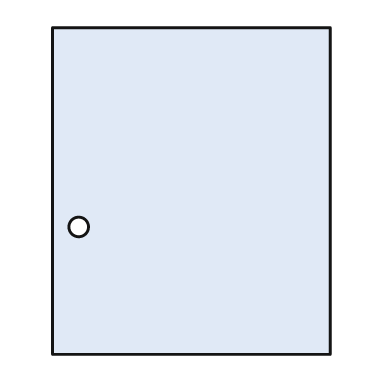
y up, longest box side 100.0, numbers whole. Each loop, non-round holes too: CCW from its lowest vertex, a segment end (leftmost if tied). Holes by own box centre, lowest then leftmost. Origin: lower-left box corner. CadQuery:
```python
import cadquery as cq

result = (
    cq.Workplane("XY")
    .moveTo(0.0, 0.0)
    .lineTo(85.0, 0.0)
    .lineTo(85.0, 100.0)
    .lineTo(0.0, 100.0)
    .close()
    .moveTo(8.0, 39.0)
    .circle(3.0)
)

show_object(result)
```